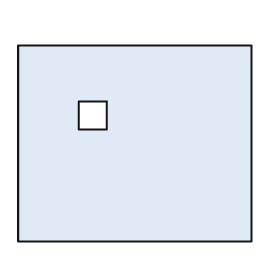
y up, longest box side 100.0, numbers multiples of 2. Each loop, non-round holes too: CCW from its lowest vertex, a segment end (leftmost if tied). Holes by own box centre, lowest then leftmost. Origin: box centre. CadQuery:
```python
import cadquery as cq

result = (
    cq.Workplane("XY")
    .moveTo(-50.0, -42.0)
    .lineTo(50.0, -42.0)
    .lineTo(50.0, 42.0)
    .lineTo(-50.0, 42.0)
    .close()
    .moveTo(-24.0, 6.0)
    .lineTo(-12.0, 6.0)
    .lineTo(-12.0, 18.0)
    .lineTo(-24.0, 18.0)
    .close()
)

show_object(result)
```